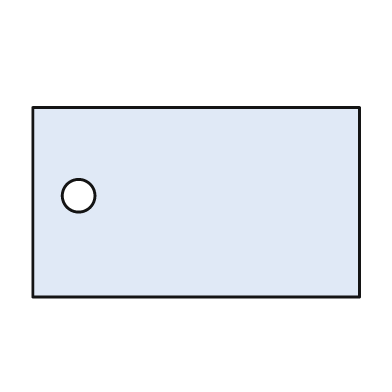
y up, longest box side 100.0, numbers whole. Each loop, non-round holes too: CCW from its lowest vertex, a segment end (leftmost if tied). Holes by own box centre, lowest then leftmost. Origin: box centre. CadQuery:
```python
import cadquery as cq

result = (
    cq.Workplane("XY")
    .moveTo(-50.0, -29.0)
    .lineTo(50.0, -29.0)
    .lineTo(50.0, 29.0)
    .lineTo(-50.0, 29.0)
    .close()
    .moveTo(-36.0, 2.0)
    .circle(5.0)
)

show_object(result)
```